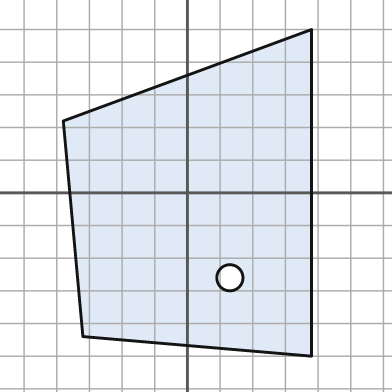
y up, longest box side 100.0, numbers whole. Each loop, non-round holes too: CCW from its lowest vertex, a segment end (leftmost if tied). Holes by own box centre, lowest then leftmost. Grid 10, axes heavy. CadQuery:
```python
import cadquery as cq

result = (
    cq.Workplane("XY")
    .moveTo(38.0, -50.0)
    .lineTo(38.0, 50.0)
    .lineTo(-38.0, 22.0)
    .lineTo(-32.0, -44.0)
    .close()
    .moveTo(13.0, -26.0)
    .circle(4.0)
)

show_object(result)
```